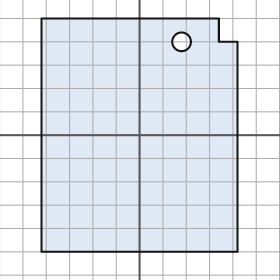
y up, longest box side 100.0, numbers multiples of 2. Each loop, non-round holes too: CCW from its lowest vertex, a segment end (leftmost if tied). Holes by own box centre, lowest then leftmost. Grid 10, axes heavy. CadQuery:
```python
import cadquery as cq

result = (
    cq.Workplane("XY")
    .moveTo(-42.0, -50.0)
    .lineTo(42.0, -50.0)
    .lineTo(42.0, 40.0)
    .lineTo(34.0, 40.0)
    .lineTo(34.0, 50.0)
    .lineTo(-42.0, 50.0)
    .close()
    .moveTo(18.0, 40.0)
    .circle(4.0)
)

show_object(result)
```